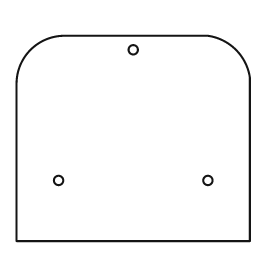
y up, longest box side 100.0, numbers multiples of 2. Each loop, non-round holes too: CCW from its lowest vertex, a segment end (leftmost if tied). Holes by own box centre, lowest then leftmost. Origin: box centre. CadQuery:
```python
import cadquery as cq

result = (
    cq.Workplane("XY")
    .moveTo(-50.0, -44.0)
    .lineTo(50.0, -44.0)
    .lineTo(50.0, 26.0)
    .threePointArc((44.0, 38.0), (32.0, 44.0))
    .lineTo(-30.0, 44.0)
    .threePointArc((-44.0, 38.0), (-50.0, 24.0))
    .close()
    .moveTo(-32.0, -18.0)
    .circle(2.0)
    .moveTo(32.0, -18.0)
    .circle(2.0)
    .moveTo(0.0, 38.0)
    .circle(2.0)
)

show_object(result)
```